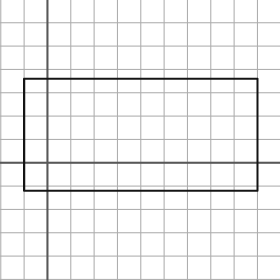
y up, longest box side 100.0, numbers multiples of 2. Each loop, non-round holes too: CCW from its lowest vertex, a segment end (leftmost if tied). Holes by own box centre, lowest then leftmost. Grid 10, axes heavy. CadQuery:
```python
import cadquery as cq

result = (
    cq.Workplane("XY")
    .moveTo(-10.0, -12.0)
    .lineTo(90.0, -12.0)
    .lineTo(90.0, 36.0)
    .lineTo(-10.0, 36.0)
    .close()
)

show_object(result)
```